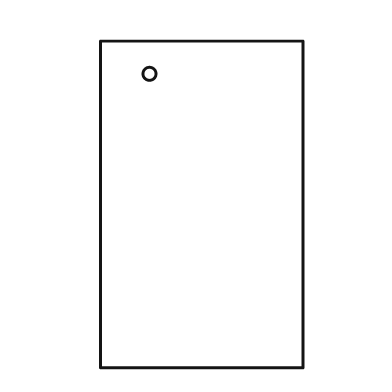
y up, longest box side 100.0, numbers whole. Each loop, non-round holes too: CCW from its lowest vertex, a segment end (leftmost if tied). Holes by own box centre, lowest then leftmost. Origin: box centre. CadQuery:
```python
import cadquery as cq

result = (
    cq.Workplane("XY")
    .moveTo(-31.0, -50.0)
    .lineTo(31.0, -50.0)
    .lineTo(31.0, 50.0)
    .lineTo(-31.0, 50.0)
    .close()
    .moveTo(-16.0, 40.0)
    .circle(2.0)
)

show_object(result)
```